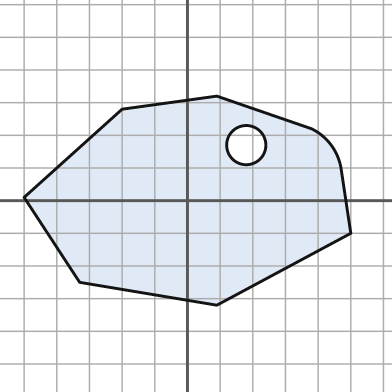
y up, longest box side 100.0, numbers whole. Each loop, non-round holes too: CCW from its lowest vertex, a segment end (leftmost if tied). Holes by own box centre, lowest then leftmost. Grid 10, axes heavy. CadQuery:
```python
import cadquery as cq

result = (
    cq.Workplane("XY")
    .moveTo(9.0, -32.0)
    .lineTo(50.0, -10.0)
    .lineTo(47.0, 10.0)
    .threePointArc((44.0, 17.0), (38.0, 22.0))
    .lineTo(9.0, 32.0)
    .lineTo(-20.0, 28.0)
    .lineTo(-50.0, 1.0)
    .lineTo(-33.0, -25.0)
    .close()
    .moveTo(18.0, 17.0)
    .circle(6.0)
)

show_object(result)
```